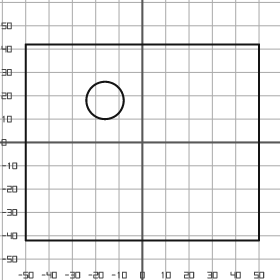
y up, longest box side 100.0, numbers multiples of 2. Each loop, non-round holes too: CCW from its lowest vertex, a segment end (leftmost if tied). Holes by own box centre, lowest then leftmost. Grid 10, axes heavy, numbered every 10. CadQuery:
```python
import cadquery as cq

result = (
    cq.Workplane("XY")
    .moveTo(-50.0, -42.0)
    .lineTo(50.0, -42.0)
    .lineTo(50.0, 42.0)
    .lineTo(-50.0, 42.0)
    .close()
    .moveTo(-16.0, 18.0)
    .circle(8.0)
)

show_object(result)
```